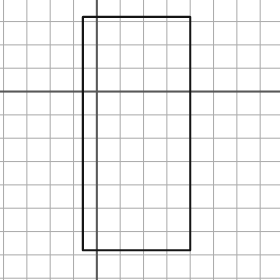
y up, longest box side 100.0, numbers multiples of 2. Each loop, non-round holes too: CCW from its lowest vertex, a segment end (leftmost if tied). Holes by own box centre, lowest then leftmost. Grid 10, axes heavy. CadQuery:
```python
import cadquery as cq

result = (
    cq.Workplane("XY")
    .moveTo(-6.0, -68.0)
    .lineTo(40.0, -68.0)
    .lineTo(40.0, 32.0)
    .lineTo(-6.0, 32.0)
    .close()
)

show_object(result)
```